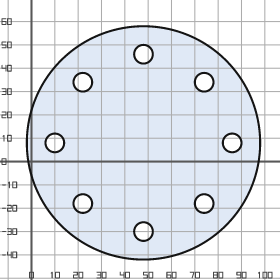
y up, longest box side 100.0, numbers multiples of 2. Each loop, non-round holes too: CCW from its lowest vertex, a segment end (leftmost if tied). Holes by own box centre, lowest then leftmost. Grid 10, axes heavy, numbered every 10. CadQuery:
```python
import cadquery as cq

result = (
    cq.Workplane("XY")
    .moveTo(48.0, 8.0)
    .circle(50.0)
    .moveTo(48.0, -30.0)
    .circle(4.0)
    .moveTo(22.0, -18.0)
    .circle(4.0)
    .moveTo(74.0, -18.0)
    .circle(4.0)
    .moveTo(10.0, 8.0)
    .circle(4.0)
    .moveTo(86.0, 8.0)
    .circle(4.0)
    .moveTo(22.0, 34.0)
    .circle(4.0)
    .moveTo(74.0, 34.0)
    .circle(4.0)
    .moveTo(48.0, 46.0)
    .circle(4.0)
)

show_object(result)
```